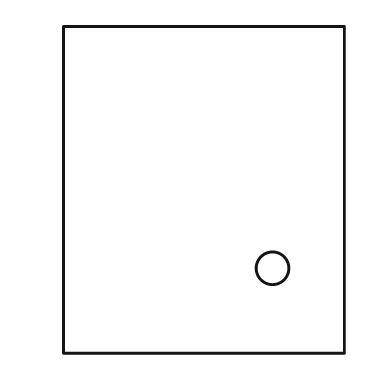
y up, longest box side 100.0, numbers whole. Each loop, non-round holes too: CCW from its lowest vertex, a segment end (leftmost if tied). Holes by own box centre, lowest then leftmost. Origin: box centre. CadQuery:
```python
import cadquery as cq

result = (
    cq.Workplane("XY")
    .moveTo(-43.0, -50.0)
    .lineTo(43.0, -50.0)
    .lineTo(43.0, 50.0)
    .lineTo(-43.0, 50.0)
    .close()
    .moveTo(21.0, -24.0)
    .circle(5.0)
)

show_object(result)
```